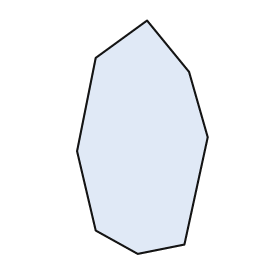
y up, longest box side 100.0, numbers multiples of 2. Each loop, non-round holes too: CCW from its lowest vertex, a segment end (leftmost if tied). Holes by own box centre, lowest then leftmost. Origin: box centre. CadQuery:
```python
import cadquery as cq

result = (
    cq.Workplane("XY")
    .moveTo(-2.0, -50.0)
    .lineTo(18.0, -46.0)
    .lineTo(28.0, 0.0)
    .lineTo(20.0, 28.0)
    .lineTo(2.0, 50.0)
    .lineTo(-20.0, 34.0)
    .lineTo(-28.0, -6.0)
    .lineTo(-20.0, -40.0)
    .close()
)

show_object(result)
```